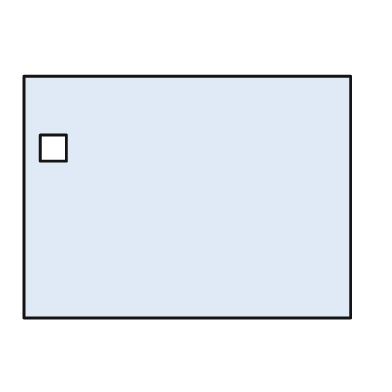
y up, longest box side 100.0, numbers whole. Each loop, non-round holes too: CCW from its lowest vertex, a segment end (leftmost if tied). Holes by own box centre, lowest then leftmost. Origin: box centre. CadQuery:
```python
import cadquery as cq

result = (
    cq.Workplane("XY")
    .moveTo(-50.0, -37.0)
    .lineTo(50.0, -37.0)
    .lineTo(50.0, 37.0)
    .lineTo(-50.0, 37.0)
    .close()
    .moveTo(-45.0, 11.0)
    .lineTo(-37.0, 11.0)
    .lineTo(-37.0, 19.0)
    .lineTo(-45.0, 19.0)
    .close()
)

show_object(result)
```